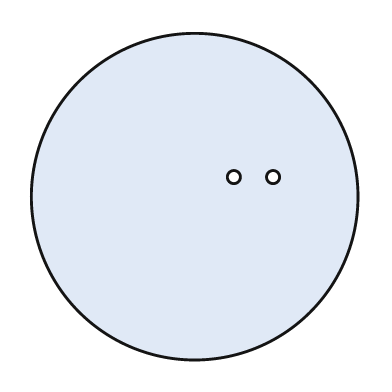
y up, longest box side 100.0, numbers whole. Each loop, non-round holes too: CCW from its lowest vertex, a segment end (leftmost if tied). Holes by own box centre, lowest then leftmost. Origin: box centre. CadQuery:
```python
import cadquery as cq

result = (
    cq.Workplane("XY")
    .moveTo(0.0, 0.0)
    .circle(50.0)
    .moveTo(12.0, 6.0)
    .circle(2.0)
    .moveTo(24.0, 6.0)
    .circle(2.0)
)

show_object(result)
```